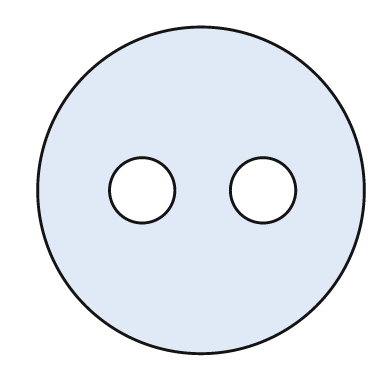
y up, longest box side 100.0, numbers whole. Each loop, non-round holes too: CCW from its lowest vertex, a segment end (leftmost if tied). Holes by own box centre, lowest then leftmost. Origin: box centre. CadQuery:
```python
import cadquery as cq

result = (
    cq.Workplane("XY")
    .moveTo(0.0, 0.0)
    .circle(50.0)
    .moveTo(-18.0, 0.0)
    .circle(10.0)
    .moveTo(19.0, 0.0)
    .circle(10.0)
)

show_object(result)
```